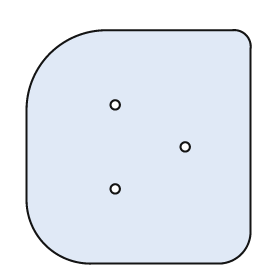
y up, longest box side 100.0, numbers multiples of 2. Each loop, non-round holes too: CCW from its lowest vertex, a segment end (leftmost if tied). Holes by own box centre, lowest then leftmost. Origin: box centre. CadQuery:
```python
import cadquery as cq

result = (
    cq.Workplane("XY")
    .moveTo(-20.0, -50.0)
    .lineTo(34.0, -50.0)
    .threePointArc((44.0, -46.0), (48.0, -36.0))
    .lineTo(48.0, 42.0)
    .threePointArc((46.0, 48.0), (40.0, 50.0))
    .lineTo(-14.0, 50.0)
    .threePointArc((-38.0, 40.0), (-48.0, 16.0))
    .lineTo(-48.0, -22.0)
    .threePointArc((-40.0, -42.0), (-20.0, -50.0))
    .close()
    .moveTo(-10.0, -18.0)
    .circle(2.0)
    .moveTo(20.0, 0.0)
    .circle(2.0)
    .moveTo(-10.0, 18.0)
    .circle(2.0)
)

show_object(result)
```